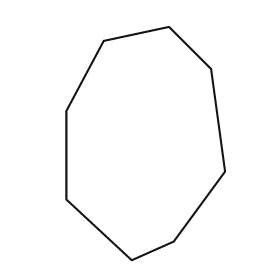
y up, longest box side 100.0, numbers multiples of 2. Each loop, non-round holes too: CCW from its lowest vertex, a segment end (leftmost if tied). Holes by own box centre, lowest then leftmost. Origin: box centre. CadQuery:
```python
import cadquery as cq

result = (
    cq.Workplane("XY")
    .moveTo(-6.0, -50.0)
    .lineTo(12.0, -42.0)
    .lineTo(34.0, -12.0)
    .lineTo(28.0, 32.0)
    .lineTo(10.0, 50.0)
    .lineTo(-18.0, 44.0)
    .lineTo(-34.0, 14.0)
    .lineTo(-34.0, -24.0)
    .close()
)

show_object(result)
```